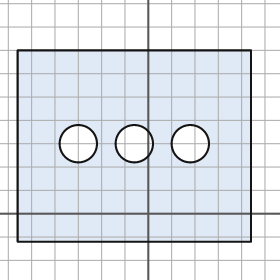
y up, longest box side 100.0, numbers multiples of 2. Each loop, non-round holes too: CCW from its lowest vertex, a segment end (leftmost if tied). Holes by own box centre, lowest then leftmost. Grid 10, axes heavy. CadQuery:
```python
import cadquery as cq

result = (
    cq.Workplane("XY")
    .moveTo(-56.0, -12.0)
    .lineTo(44.0, -12.0)
    .lineTo(44.0, 70.0)
    .lineTo(-56.0, 70.0)
    .close()
    .moveTo(-30.0, 30.0)
    .circle(8.0)
    .moveTo(-6.0, 30.0)
    .circle(8.0)
    .moveTo(18.0, 30.0)
    .circle(8.0)
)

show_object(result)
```